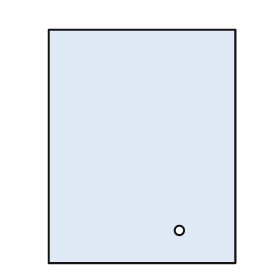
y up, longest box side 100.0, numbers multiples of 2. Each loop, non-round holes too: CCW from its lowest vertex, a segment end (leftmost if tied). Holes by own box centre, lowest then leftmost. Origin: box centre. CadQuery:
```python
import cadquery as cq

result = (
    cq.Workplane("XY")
    .moveTo(-40.0, -50.0)
    .lineTo(40.0, -50.0)
    .lineTo(40.0, 50.0)
    .lineTo(-40.0, 50.0)
    .close()
    .moveTo(16.0, -36.0)
    .circle(2.0)
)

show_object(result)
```